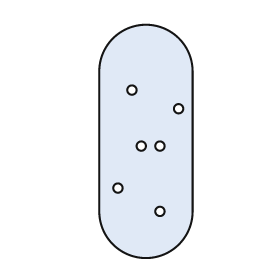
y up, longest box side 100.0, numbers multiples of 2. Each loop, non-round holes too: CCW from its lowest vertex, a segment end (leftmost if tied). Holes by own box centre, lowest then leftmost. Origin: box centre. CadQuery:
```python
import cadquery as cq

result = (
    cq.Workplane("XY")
    .moveTo(-20.0, -30.0)
    .threePointArc((0.0, -50.0), (20.0, -30.0))
    .lineTo(20.0, 30.0)
    .threePointArc((0.0, 50.0), (-20.0, 30.0))
    .close()
    .moveTo(6.0, -30.0)
    .circle(2.0)
    .moveTo(-12.0, -20.0)
    .circle(2.0)
    .moveTo(-2.0, -2.0)
    .circle(2.0)
    .moveTo(6.0, -2.0)
    .circle(2.0)
    .moveTo(14.0, 14.0)
    .circle(2.0)
    .moveTo(-6.0, 22.0)
    .circle(2.0)
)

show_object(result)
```